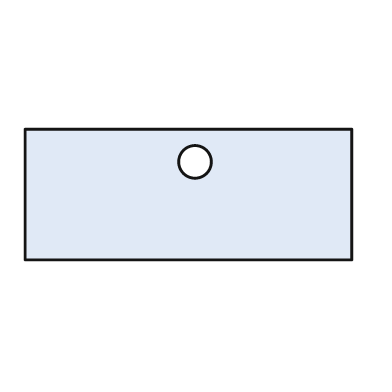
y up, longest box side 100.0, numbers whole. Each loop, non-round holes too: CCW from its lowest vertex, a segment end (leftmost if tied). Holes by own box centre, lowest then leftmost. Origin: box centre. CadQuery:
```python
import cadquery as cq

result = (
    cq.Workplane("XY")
    .moveTo(-50.0, -20.0)
    .lineTo(50.0, -20.0)
    .lineTo(50.0, 20.0)
    .lineTo(-50.0, 20.0)
    .close()
    .moveTo(2.0, 10.0)
    .circle(5.0)
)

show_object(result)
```